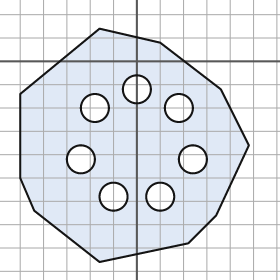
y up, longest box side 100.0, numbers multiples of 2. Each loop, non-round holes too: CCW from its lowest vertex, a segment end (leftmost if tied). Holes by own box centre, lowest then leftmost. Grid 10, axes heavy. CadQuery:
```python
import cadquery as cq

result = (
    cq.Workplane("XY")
    .moveTo(-16.0, -86.0)
    .lineTo(22.0, -78.0)
    .lineTo(34.0, -66.0)
    .lineTo(48.0, -36.0)
    .lineTo(36.0, -12.0)
    .lineTo(10.0, 8.0)
    .lineTo(-16.0, 14.0)
    .lineTo(-50.0, -14.0)
    .lineTo(-50.0, -50.0)
    .lineTo(-44.0, -64.0)
    .close()
    .moveTo(-10.0, -58.0)
    .circle(6.0)
    .moveTo(10.0, -58.0)
    .circle(6.0)
    .moveTo(-24.0, -42.0)
    .circle(6.0)
    .moveTo(24.0, -42.0)
    .circle(6.0)
    .moveTo(-18.0, -20.0)
    .circle(6.0)
    .moveTo(18.0, -20.0)
    .circle(6.0)
    .moveTo(0.0, -12.0)
    .circle(6.0)
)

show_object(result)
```